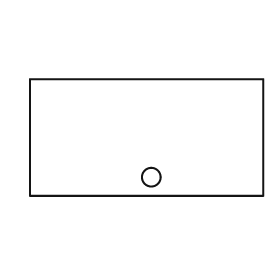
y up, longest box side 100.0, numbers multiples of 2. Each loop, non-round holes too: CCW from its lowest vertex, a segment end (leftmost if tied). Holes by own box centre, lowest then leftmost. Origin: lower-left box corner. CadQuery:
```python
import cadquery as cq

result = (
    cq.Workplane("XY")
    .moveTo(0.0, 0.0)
    .lineTo(100.0, 0.0)
    .lineTo(100.0, 50.0)
    .lineTo(0.0, 50.0)
    .close()
    .moveTo(52.0, 8.0)
    .circle(4.0)
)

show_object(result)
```